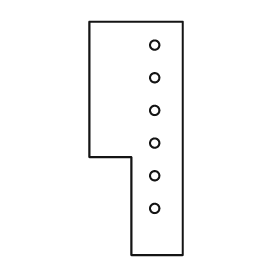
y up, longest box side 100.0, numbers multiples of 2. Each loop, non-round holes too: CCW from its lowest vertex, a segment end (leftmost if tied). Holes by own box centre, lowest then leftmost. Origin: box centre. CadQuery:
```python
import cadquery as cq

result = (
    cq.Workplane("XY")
    .moveTo(-2.0, -50.0)
    .lineTo(20.0, -50.0)
    .lineTo(20.0, 50.0)
    .lineTo(-20.0, 50.0)
    .lineTo(-20.0, -8.0)
    .lineTo(-2.0, -8.0)
    .close()
    .moveTo(8.0, -30.0)
    .circle(2.0)
    .moveTo(8.0, -16.0)
    .circle(2.0)
    .moveTo(8.0, -2.0)
    .circle(2.0)
    .moveTo(8.0, 12.0)
    .circle(2.0)
    .moveTo(8.0, 26.0)
    .circle(2.0)
    .moveTo(8.0, 40.0)
    .circle(2.0)
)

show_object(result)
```